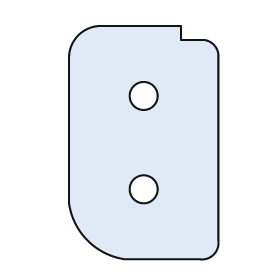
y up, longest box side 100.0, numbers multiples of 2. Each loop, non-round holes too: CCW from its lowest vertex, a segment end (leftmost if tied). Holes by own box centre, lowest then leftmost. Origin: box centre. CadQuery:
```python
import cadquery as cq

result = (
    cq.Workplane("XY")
    .moveTo(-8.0, -50.0)
    .lineTo(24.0, -50.0)
    .threePointArc((30.0, -48.0), (32.0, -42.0))
    .lineTo(32.0, 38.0)
    .threePointArc((30.0, 42.0), (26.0, 44.0))
    .lineTo(16.0, 44.0)
    .lineTo(16.0, 50.0)
    .lineTo(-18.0, 50.0)
    .threePointArc((-28.0, 46.0), (-32.0, 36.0))
    .lineTo(-32.0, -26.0)
    .threePointArc((-24.0, -42.0), (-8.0, -50.0))
    .close()
    .moveTo(0.0, -20.0)
    .circle(6.0)
    .moveTo(0.0, 20.0)
    .circle(6.0)
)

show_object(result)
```